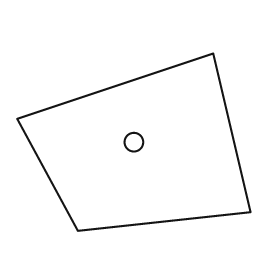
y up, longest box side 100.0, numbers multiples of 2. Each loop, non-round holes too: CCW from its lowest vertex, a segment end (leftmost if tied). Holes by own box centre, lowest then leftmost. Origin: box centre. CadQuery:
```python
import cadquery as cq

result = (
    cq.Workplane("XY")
    .moveTo(-24.0, -38.0)
    .lineTo(50.0, -30.0)
    .lineTo(34.0, 38.0)
    .lineTo(-50.0, 10.0)
    .close()
    .moveTo(0.0, 0.0)
    .circle(4.0)
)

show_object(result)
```